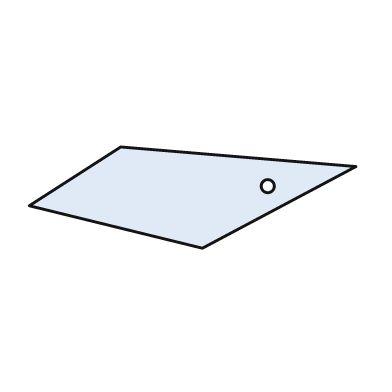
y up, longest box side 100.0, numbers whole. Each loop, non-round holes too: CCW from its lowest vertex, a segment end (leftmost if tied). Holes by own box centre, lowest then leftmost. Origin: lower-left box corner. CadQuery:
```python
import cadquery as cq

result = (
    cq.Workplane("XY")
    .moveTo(53.0, 0.0)
    .lineTo(100.0, 25.0)
    .lineTo(28.0, 31.0)
    .lineTo(0.0, 13.0)
    .close()
    .moveTo(73.0, 19.0)
    .circle(2.0)
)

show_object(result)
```